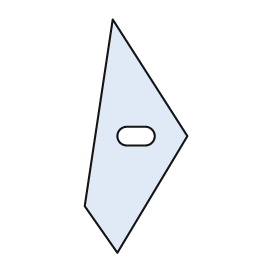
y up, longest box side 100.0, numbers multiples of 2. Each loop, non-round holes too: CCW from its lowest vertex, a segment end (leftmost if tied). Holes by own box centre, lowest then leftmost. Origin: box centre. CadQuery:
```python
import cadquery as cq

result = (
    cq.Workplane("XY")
    .moveTo(-8.0, -50.0)
    .lineTo(22.0, 0.0)
    .lineTo(-10.0, 50.0)
    .lineTo(-22.0, -30.0)
    .close()
    .moveTo(-4.0, -4.0)
    .lineTo(4.0, -4.0)
    .threePointArc((8.0, 0.0), (4.0, 4.0))
    .lineTo(-4.0, 4.0)
    .threePointArc((-8.0, 0.0), (-4.0, -4.0))
    .close()
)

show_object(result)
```